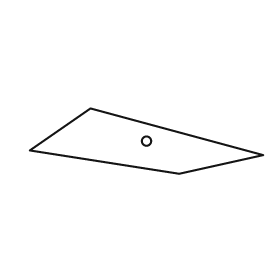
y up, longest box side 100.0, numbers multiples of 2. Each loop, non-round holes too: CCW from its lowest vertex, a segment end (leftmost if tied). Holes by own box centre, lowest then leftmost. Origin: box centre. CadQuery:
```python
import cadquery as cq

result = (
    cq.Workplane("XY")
    .moveTo(14.0, -14.0)
    .lineTo(50.0, -6.0)
    .lineTo(-24.0, 14.0)
    .lineTo(-50.0, -4.0)
    .close()
    .moveTo(0.0, 0.0)
    .circle(2.0)
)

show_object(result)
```